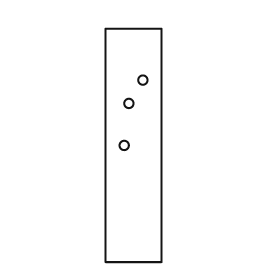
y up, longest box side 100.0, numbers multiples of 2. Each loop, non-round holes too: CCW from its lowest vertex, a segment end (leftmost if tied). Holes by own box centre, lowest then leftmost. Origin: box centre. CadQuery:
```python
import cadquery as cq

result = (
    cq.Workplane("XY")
    .moveTo(-12.0, -50.0)
    .lineTo(12.0, -50.0)
    .lineTo(12.0, 50.0)
    .lineTo(-12.0, 50.0)
    .close()
    .moveTo(-4.0, 0.0)
    .circle(2.0)
    .moveTo(-2.0, 18.0)
    .circle(2.0)
    .moveTo(4.0, 28.0)
    .circle(2.0)
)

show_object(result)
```